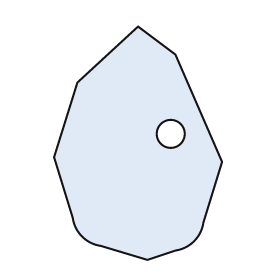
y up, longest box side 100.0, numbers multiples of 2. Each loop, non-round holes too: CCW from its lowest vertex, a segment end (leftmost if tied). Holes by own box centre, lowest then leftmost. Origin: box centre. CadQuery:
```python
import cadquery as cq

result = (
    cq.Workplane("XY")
    .moveTo(4.0, -50.0)
    .lineTo(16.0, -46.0)
    .threePointArc((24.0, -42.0), (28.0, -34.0))
    .lineTo(36.0, -8.0)
    .lineTo(16.0, 38.0)
    .lineTo(0.0, 50.0)
    .lineTo(-26.0, 26.0)
    .lineTo(-36.0, -6.0)
    .lineTo(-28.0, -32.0)
    .threePointArc((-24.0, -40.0), (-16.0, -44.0))
    .close()
    .moveTo(14.0, 4.0)
    .circle(6.0)
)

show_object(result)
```